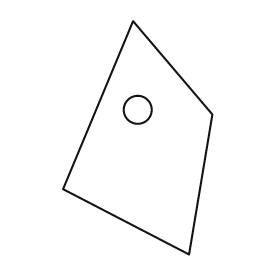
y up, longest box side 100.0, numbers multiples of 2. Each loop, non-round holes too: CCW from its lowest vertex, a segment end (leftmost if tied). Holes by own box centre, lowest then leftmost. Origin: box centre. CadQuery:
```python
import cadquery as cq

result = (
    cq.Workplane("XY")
    .moveTo(22.0, -50.0)
    .lineTo(32.0, 10.0)
    .lineTo(-2.0, 50.0)
    .lineTo(-32.0, -22.0)
    .close()
    .moveTo(0.0, 12.0)
    .circle(6.0)
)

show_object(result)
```